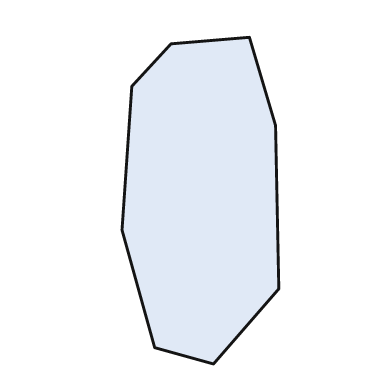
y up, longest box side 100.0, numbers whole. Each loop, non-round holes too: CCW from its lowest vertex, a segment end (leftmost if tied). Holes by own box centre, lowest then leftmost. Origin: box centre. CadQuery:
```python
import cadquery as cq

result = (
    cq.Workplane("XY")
    .moveTo(4.0, -50.0)
    .lineTo(24.0, -27.0)
    .lineTo(23.0, 23.0)
    .lineTo(15.0, 50.0)
    .lineTo(-9.0, 48.0)
    .lineTo(-21.0, 35.0)
    .lineTo(-24.0, -9.0)
    .lineTo(-14.0, -45.0)
    .close()
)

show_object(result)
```